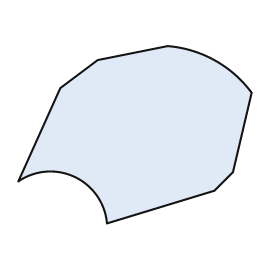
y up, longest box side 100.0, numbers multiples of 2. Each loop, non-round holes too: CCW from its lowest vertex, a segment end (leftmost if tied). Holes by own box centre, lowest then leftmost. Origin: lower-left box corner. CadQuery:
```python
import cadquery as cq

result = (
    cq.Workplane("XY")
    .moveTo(38.0, 0.0)
    .lineTo(84.0, 14.0)
    .lineTo(92.0, 22.0)
    .lineTo(100.0, 56.0)
    .threePointArc((84.0, 70.0), (64.0, 76.0))
    .lineTo(34.0, 70.0)
    .lineTo(18.0, 58.0)
    .lineTo(0.0, 18.0)
    .threePointArc((24.0, 20.0), (38.0, 0.0))
    .close()
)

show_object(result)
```